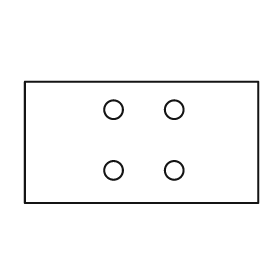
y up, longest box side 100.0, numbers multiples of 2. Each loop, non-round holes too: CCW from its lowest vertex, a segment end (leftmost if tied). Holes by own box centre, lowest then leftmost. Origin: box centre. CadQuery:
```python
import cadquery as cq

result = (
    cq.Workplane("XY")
    .moveTo(-50.0, -26.0)
    .lineTo(50.0, -26.0)
    .lineTo(50.0, 26.0)
    .lineTo(-50.0, 26.0)
    .close()
    .moveTo(-12.0, -12.0)
    .circle(4.0)
    .moveTo(14.0, -12.0)
    .circle(4.0)
    .moveTo(-12.0, 14.0)
    .circle(4.0)
    .moveTo(14.0, 14.0)
    .circle(4.0)
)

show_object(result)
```